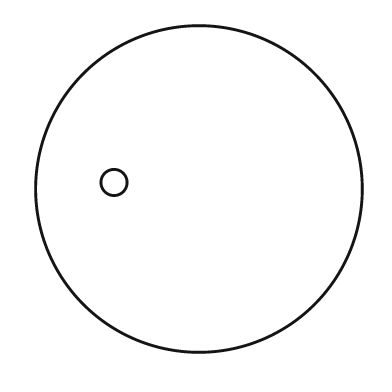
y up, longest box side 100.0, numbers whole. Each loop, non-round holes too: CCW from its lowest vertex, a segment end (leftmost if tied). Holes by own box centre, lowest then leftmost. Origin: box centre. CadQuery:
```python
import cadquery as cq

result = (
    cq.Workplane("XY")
    .moveTo(0.0, 0.0)
    .circle(50.0)
    .moveTo(-26.0, 2.0)
    .circle(4.0)
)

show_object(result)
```